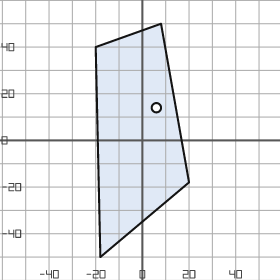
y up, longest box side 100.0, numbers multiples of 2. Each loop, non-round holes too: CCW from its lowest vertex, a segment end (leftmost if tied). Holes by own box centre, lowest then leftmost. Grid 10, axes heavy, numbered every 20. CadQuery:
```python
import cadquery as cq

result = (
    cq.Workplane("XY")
    .moveTo(-18.0, -50.0)
    .lineTo(20.0, -18.0)
    .lineTo(8.0, 50.0)
    .lineTo(-20.0, 40.0)
    .close()
    .moveTo(6.0, 14.0)
    .circle(2.0)
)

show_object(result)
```